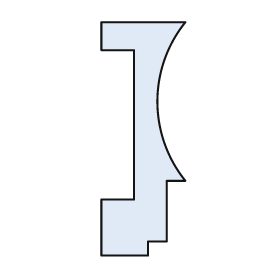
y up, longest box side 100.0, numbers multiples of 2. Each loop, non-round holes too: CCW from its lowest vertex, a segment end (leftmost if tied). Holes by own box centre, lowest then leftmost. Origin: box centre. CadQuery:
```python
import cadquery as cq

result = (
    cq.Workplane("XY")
    .moveTo(-18.0, -50.0)
    .lineTo(2.0, -50.0)
    .lineTo(2.0, -44.0)
    .lineTo(10.0, -44.0)
    .lineTo(10.0, -18.0)
    .lineTo(18.0, -18.0)
    .threePointArc((6.0, 16.0), (18.0, 50.0))
    .lineTo(-18.0, 50.0)
    .lineTo(-18.0, 38.0)
    .lineTo(-4.0, 38.0)
    .lineTo(-4.0, -26.0)
    .lineTo(-18.0, -26.0)
    .close()
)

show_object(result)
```